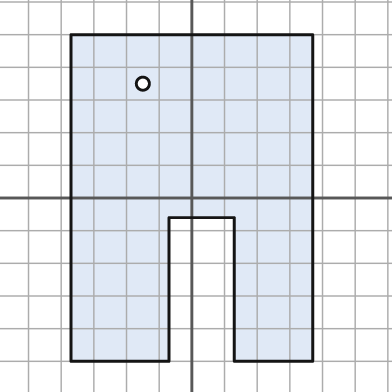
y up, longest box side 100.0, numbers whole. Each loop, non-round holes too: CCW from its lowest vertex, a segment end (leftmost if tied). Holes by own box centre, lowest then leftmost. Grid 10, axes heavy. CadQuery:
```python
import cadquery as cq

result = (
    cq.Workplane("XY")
    .moveTo(-37.0, -50.0)
    .lineTo(-7.0, -50.0)
    .lineTo(-7.0, -6.0)
    .lineTo(13.0, -6.0)
    .lineTo(13.0, -50.0)
    .lineTo(37.0, -50.0)
    .lineTo(37.0, 50.0)
    .lineTo(-37.0, 50.0)
    .close()
    .moveTo(-15.0, 35.0)
    .circle(2.0)
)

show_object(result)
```